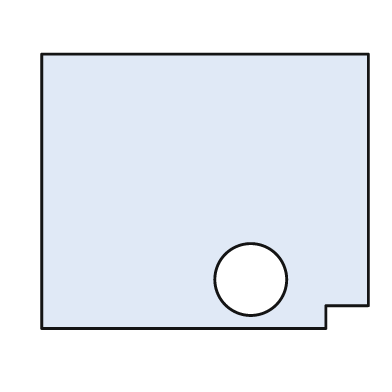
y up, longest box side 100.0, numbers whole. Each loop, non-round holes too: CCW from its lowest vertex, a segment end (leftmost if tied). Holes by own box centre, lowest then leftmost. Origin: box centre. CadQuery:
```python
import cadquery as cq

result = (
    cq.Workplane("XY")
    .moveTo(-50.0, -42.0)
    .lineTo(37.0, -42.0)
    .lineTo(37.0, -35.0)
    .lineTo(50.0, -35.0)
    .lineTo(50.0, 42.0)
    .lineTo(-50.0, 42.0)
    .close()
    .moveTo(14.0, -27.0)
    .circle(11.0)
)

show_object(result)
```